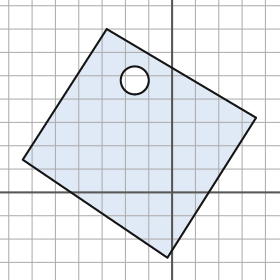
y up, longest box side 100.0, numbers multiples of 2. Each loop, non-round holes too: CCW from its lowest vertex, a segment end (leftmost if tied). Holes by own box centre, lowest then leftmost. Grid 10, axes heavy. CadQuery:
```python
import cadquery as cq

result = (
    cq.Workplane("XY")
    .moveTo(-2.0, -28.0)
    .lineTo(36.0, 32.0)
    .lineTo(-28.0, 70.0)
    .lineTo(-64.0, 14.0)
    .close()
    .moveTo(-16.0, 48.0)
    .circle(6.0)
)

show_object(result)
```